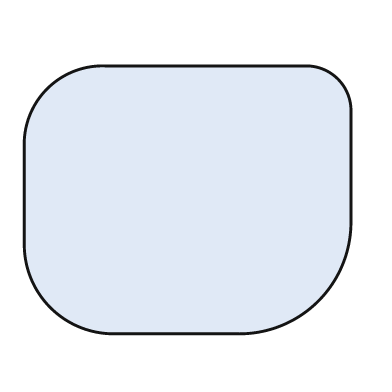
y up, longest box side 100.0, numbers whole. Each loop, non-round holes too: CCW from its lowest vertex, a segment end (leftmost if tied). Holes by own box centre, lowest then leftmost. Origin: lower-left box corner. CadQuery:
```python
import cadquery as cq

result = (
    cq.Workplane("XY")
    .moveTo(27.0, 0.0)
    .lineTo(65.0, 0.0)
    .threePointArc((90.0, 10.0), (100.0, 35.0))
    .lineTo(100.0, 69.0)
    .threePointArc((96.0, 78.0), (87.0, 82.0))
    .lineTo(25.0, 82.0)
    .threePointArc((7.0, 75.0), (0.0, 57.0))
    .lineTo(0.0, 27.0)
    .threePointArc((8.0, 8.0), (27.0, 0.0))
    .close()
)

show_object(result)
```